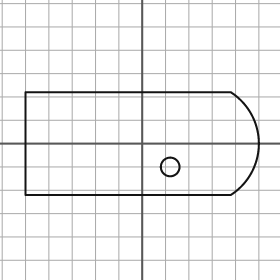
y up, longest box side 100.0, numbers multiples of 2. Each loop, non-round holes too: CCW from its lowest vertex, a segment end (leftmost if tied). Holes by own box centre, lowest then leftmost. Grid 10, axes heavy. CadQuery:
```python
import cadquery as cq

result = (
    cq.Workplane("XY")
    .moveTo(-50.0, -22.0)
    .lineTo(38.0, -22.0)
    .threePointArc((50.0, 0.0), (38.0, 22.0))
    .lineTo(-50.0, 22.0)
    .close()
    .moveTo(12.0, -10.0)
    .circle(4.0)
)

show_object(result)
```